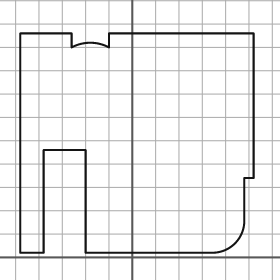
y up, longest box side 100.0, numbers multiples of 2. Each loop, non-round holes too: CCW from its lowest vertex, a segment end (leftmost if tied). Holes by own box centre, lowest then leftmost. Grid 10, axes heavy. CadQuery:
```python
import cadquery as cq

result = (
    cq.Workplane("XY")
    .moveTo(-48.0, 2.0)
    .lineTo(-38.0, 2.0)
    .lineTo(-38.0, 46.0)
    .lineTo(-20.0, 46.0)
    .lineTo(-20.0, 2.0)
    .lineTo(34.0, 2.0)
    .threePointArc((44.0, 6.0), (48.0, 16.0))
    .lineTo(48.0, 34.0)
    .lineTo(52.0, 34.0)
    .lineTo(52.0, 96.0)
    .lineTo(-10.0, 96.0)
    .lineTo(-10.0, 90.0)
    .threePointArc((-18.0, 92.0), (-26.0, 90.0))
    .lineTo(-26.0, 96.0)
    .lineTo(-48.0, 96.0)
    .close()
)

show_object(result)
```